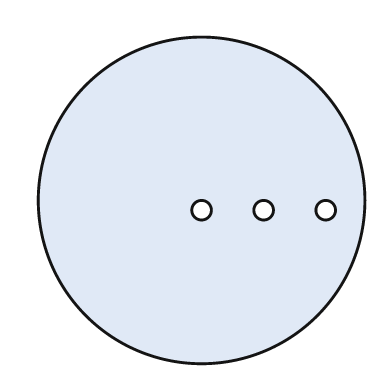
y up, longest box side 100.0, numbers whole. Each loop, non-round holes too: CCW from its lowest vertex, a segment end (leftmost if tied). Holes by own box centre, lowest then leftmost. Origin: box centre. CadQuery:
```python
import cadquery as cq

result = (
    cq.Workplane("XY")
    .moveTo(0.0, 0.0)
    .circle(50.0)
    .moveTo(0.0, -3.0)
    .circle(3.0)
    .moveTo(19.0, -3.0)
    .circle(3.0)
    .moveTo(38.0, -3.0)
    .circle(3.0)
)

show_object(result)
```